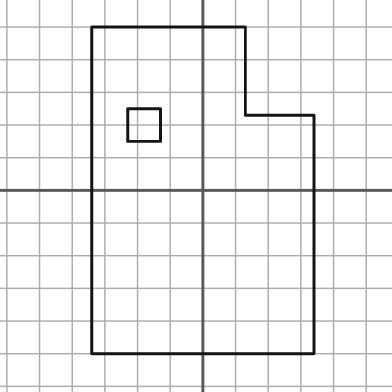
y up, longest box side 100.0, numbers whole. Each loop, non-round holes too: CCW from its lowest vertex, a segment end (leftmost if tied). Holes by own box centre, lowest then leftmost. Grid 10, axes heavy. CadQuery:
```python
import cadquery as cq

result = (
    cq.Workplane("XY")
    .moveTo(-34.0, -50.0)
    .lineTo(34.0, -50.0)
    .lineTo(34.0, 23.0)
    .lineTo(13.0, 23.0)
    .lineTo(13.0, 50.0)
    .lineTo(-34.0, 50.0)
    .close()
    .moveTo(-23.0, 15.0)
    .lineTo(-13.0, 15.0)
    .lineTo(-13.0, 25.0)
    .lineTo(-23.0, 25.0)
    .close()
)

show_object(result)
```